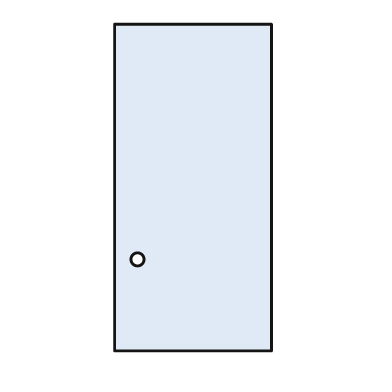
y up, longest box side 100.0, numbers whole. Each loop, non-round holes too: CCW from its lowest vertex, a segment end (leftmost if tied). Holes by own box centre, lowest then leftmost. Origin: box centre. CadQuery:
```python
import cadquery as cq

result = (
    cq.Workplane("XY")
    .moveTo(-24.0, -50.0)
    .lineTo(24.0, -50.0)
    .lineTo(24.0, 50.0)
    .lineTo(-24.0, 50.0)
    .close()
    .moveTo(-17.0, -22.0)
    .circle(2.0)
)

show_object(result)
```